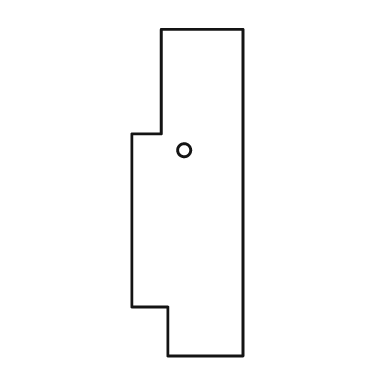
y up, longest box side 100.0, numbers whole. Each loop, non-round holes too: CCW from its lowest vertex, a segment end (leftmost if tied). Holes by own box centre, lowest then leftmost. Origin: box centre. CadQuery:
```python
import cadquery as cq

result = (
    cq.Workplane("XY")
    .moveTo(-6.0, -50.0)
    .lineTo(17.0, -50.0)
    .lineTo(17.0, 50.0)
    .lineTo(-8.0, 50.0)
    .lineTo(-8.0, 18.0)
    .lineTo(-17.0, 18.0)
    .lineTo(-17.0, -35.0)
    .lineTo(-6.0, -35.0)
    .close()
    .moveTo(-1.0, 13.0)
    .circle(2.0)
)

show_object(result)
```